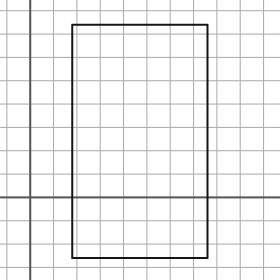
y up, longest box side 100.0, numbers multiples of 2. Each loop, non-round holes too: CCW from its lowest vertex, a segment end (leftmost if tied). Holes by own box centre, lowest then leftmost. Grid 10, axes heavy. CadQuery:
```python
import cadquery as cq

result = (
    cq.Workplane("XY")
    .moveTo(18.0, -26.0)
    .lineTo(76.0, -26.0)
    .lineTo(76.0, 74.0)
    .lineTo(18.0, 74.0)
    .close()
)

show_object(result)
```